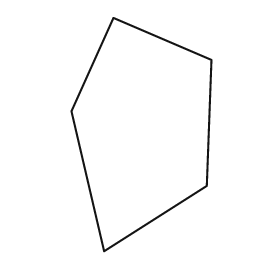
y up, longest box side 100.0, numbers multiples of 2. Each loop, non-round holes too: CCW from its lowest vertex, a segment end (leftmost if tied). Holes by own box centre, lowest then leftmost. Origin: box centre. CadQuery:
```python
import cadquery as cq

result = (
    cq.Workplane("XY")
    .moveTo(-16.0, -50.0)
    .lineTo(28.0, -22.0)
    .lineTo(30.0, 32.0)
    .lineTo(-12.0, 50.0)
    .lineTo(-30.0, 10.0)
    .close()
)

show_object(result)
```